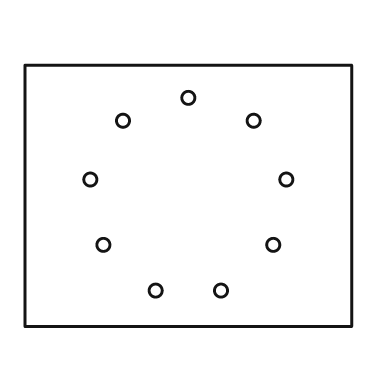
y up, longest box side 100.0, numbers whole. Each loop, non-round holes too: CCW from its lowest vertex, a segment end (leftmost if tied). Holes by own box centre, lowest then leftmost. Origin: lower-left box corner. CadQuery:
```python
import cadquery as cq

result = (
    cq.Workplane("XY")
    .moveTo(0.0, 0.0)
    .lineTo(100.0, 0.0)
    .lineTo(100.0, 80.0)
    .lineTo(0.0, 80.0)
    .close()
    .moveTo(40.0, 11.0)
    .circle(2.0)
    .moveTo(60.0, 11.0)
    .circle(2.0)
    .moveTo(24.0, 25.0)
    .circle(2.0)
    .moveTo(76.0, 25.0)
    .circle(2.0)
    .moveTo(20.0, 45.0)
    .circle(2.0)
    .moveTo(80.0, 45.0)
    .circle(2.0)
    .moveTo(30.0, 63.0)
    .circle(2.0)
    .moveTo(70.0, 63.0)
    .circle(2.0)
    .moveTo(50.0, 70.0)
    .circle(2.0)
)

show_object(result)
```